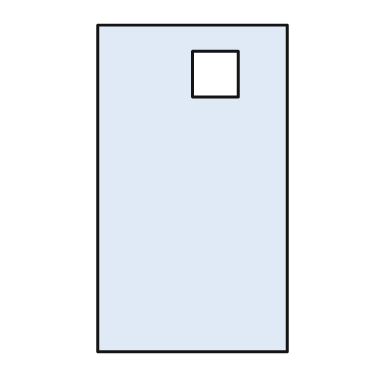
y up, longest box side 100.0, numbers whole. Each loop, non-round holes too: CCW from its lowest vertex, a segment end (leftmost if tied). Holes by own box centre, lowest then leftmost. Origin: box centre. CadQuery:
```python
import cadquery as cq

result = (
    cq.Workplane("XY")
    .moveTo(-29.0, -50.0)
    .lineTo(29.0, -50.0)
    .lineTo(29.0, 50.0)
    .lineTo(-29.0, 50.0)
    .close()
    .moveTo(0.0, 28.0)
    .lineTo(14.0, 28.0)
    .lineTo(14.0, 42.0)
    .lineTo(0.0, 42.0)
    .close()
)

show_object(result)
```